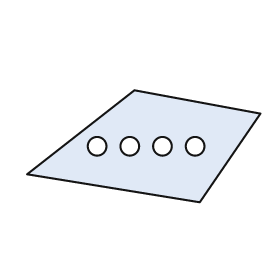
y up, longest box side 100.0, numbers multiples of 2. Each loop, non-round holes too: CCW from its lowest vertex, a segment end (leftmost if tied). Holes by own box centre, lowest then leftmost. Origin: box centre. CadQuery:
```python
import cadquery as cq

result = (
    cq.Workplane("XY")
    .moveTo(24.0, -24.0)
    .lineTo(50.0, 14.0)
    .lineTo(-4.0, 24.0)
    .lineTo(-50.0, -12.0)
    .close()
    .moveTo(-20.0, 0.0)
    .circle(4.0)
    .moveTo(-6.0, 0.0)
    .circle(4.0)
    .moveTo(8.0, 0.0)
    .circle(4.0)
    .moveTo(22.0, 0.0)
    .circle(4.0)
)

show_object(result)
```